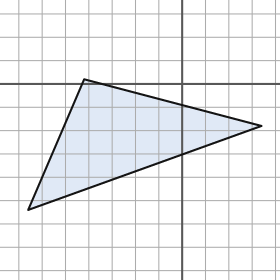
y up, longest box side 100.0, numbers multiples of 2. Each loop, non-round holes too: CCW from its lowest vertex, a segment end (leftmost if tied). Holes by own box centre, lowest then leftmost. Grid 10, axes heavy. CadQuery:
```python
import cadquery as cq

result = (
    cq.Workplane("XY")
    .moveTo(-66.0, -54.0)
    .lineTo(34.0, -18.0)
    .lineTo(-42.0, 2.0)
    .close()
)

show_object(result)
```